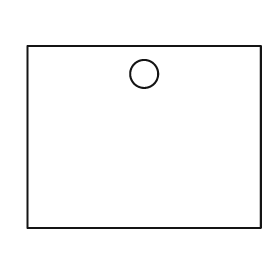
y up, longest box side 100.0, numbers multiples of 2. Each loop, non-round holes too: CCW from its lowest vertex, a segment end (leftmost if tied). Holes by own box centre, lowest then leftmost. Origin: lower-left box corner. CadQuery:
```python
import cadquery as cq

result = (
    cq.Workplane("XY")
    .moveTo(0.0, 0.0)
    .lineTo(100.0, 0.0)
    .lineTo(100.0, 78.0)
    .lineTo(0.0, 78.0)
    .close()
    .moveTo(50.0, 66.0)
    .circle(6.0)
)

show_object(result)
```